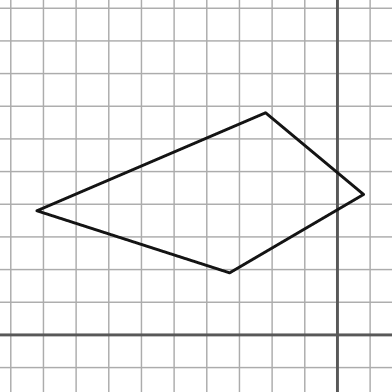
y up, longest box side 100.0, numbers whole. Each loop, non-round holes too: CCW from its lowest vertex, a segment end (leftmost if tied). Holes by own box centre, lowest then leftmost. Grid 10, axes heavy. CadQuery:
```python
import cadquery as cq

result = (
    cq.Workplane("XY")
    .moveTo(-33.0, 19.0)
    .lineTo(8.0, 43.0)
    .lineTo(-22.0, 68.0)
    .lineTo(-92.0, 38.0)
    .close()
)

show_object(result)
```